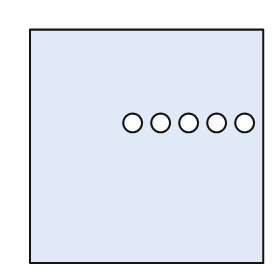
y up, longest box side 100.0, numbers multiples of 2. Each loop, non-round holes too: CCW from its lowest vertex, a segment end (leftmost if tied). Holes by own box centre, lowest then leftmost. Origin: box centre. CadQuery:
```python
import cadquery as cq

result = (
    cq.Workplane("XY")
    .moveTo(-50.0, -50.0)
    .lineTo(50.0, -50.0)
    .lineTo(50.0, 50.0)
    .lineTo(-50.0, 50.0)
    .close()
    .moveTo(-6.0, 10.0)
    .circle(4.0)
    .moveTo(6.0, 10.0)
    .circle(4.0)
    .moveTo(18.0, 10.0)
    .circle(4.0)
    .moveTo(30.0, 10.0)
    .circle(4.0)
    .moveTo(42.0, 10.0)
    .circle(4.0)
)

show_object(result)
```